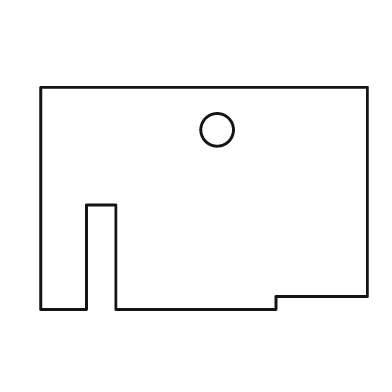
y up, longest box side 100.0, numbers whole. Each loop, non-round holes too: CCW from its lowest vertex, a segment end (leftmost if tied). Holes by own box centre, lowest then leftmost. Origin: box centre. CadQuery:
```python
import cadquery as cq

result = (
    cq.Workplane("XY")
    .moveTo(-50.0, -34.0)
    .lineTo(-36.0, -34.0)
    .lineTo(-36.0, -2.0)
    .lineTo(-27.0, -2.0)
    .lineTo(-27.0, -34.0)
    .lineTo(22.0, -34.0)
    .lineTo(22.0, -30.0)
    .lineTo(50.0, -30.0)
    .lineTo(50.0, 34.0)
    .lineTo(-50.0, 34.0)
    .close()
    .moveTo(4.0, 21.0)
    .circle(5.0)
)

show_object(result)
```